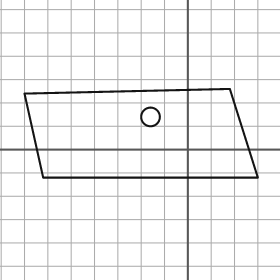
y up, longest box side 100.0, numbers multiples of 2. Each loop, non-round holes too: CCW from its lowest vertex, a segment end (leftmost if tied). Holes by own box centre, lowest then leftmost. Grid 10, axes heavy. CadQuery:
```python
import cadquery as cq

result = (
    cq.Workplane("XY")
    .moveTo(-62.0, -12.0)
    .lineTo(30.0, -12.0)
    .lineTo(18.0, 26.0)
    .lineTo(-70.0, 24.0)
    .close()
    .moveTo(-16.0, 14.0)
    .circle(4.0)
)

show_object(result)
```